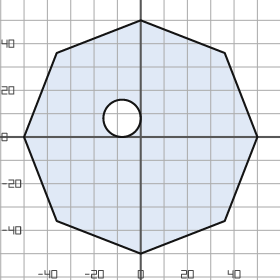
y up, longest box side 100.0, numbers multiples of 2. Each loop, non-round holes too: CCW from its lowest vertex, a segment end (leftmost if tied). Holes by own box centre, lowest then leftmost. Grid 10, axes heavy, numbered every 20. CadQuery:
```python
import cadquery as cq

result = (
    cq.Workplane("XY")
    .moveTo(0.0, -50.0)
    .lineTo(36.0, -36.0)
    .lineTo(50.0, 0.0)
    .lineTo(36.0, 36.0)
    .lineTo(0.0, 50.0)
    .lineTo(-36.0, 36.0)
    .lineTo(-50.0, 0.0)
    .lineTo(-36.0, -36.0)
    .close()
    .moveTo(-8.0, 8.0)
    .circle(8.0)
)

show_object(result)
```